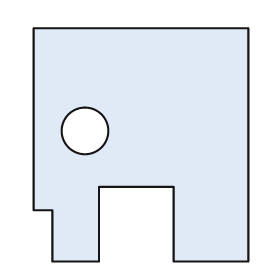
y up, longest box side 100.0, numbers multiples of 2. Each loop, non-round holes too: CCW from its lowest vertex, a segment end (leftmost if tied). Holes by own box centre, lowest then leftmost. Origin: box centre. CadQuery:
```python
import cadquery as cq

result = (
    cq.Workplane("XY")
    .moveTo(-38.0, -50.0)
    .lineTo(-18.0, -50.0)
    .lineTo(-18.0, -18.0)
    .lineTo(14.0, -18.0)
    .lineTo(14.0, -50.0)
    .lineTo(46.0, -50.0)
    .lineTo(46.0, 50.0)
    .lineTo(-46.0, 50.0)
    .lineTo(-46.0, -28.0)
    .lineTo(-38.0, -28.0)
    .close()
    .moveTo(-24.0, 6.0)
    .circle(10.0)
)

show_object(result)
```